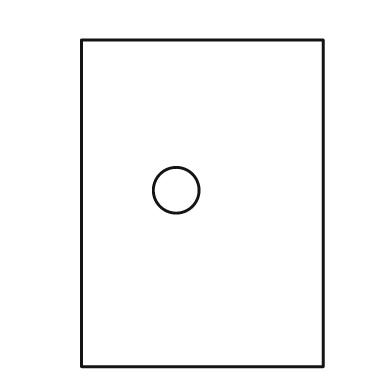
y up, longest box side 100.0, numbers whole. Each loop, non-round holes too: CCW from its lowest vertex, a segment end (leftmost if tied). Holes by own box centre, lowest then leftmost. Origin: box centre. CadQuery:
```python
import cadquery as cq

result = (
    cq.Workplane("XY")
    .moveTo(-37.0, -50.0)
    .lineTo(37.0, -50.0)
    .lineTo(37.0, 50.0)
    .lineTo(-37.0, 50.0)
    .close()
    .moveTo(-8.0, 4.0)
    .circle(7.0)
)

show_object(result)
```